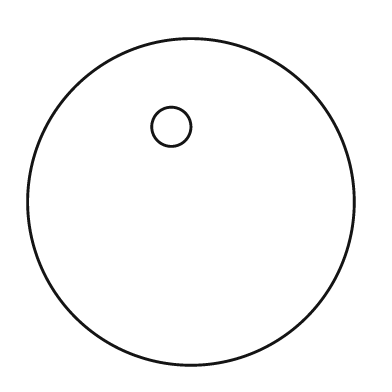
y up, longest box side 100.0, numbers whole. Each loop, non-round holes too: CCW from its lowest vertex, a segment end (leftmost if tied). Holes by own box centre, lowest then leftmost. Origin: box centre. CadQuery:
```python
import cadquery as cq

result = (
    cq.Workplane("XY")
    .moveTo(0.0, 0.0)
    .circle(50.0)
    .moveTo(-6.0, 23.0)
    .circle(6.0)
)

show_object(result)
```